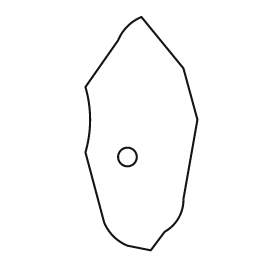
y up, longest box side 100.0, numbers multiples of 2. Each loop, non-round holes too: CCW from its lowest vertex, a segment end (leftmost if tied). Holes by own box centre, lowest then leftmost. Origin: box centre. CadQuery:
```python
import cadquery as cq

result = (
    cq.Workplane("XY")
    .moveTo(4.0, -50.0)
    .lineTo(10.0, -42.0)
    .threePointArc((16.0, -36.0), (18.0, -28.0))
    .lineTo(24.0, 6.0)
    .lineTo(18.0, 28.0)
    .lineTo(0.0, 50.0)
    .threePointArc((-6.0, 46.0), (-10.0, 40.0))
    .lineTo(-24.0, 20.0)
    .threePointArc((-22.0, 6.0), (-24.0, -8.0))
    .lineTo(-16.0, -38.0)
    .threePointArc((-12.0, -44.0), (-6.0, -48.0))
    .close()
    .moveTo(-6.0, -10.0)
    .circle(4.0)
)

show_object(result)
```